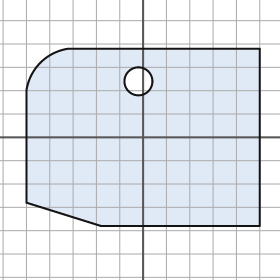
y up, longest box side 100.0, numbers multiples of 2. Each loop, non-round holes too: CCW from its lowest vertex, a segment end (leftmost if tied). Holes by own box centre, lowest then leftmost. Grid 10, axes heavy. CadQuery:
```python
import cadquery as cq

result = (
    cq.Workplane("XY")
    .moveTo(-18.0, -38.0)
    .lineTo(50.0, -38.0)
    .lineTo(50.0, 38.0)
    .lineTo(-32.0, 38.0)
    .threePointArc((-44.0, 32.0), (-50.0, 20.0))
    .lineTo(-50.0, -28.0)
    .close()
    .moveTo(-2.0, 24.0)
    .circle(6.0)
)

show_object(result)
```